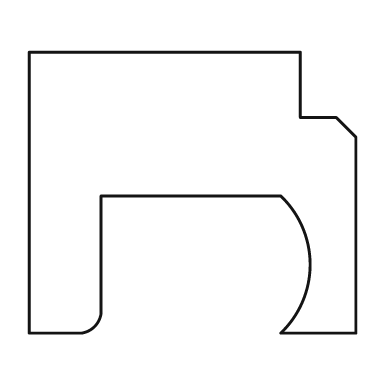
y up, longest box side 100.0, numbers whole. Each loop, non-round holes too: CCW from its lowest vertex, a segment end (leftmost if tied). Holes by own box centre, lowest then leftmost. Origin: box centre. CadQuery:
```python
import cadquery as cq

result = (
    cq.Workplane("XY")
    .moveTo(-50.0, -43.0)
    .lineTo(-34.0, -43.0)
    .threePointArc((-30.0, -41.0), (-28.0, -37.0))
    .lineTo(-28.0, -1.0)
    .lineTo(27.0, -1.0)
    .threePointArc((36.0, -22.0), (27.0, -43.0))
    .lineTo(50.0, -43.0)
    .lineTo(50.0, 17.0)
    .lineTo(44.0, 23.0)
    .lineTo(33.0, 23.0)
    .lineTo(33.0, 43.0)
    .lineTo(-50.0, 43.0)
    .close()
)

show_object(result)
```